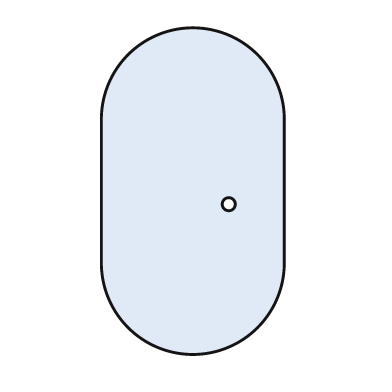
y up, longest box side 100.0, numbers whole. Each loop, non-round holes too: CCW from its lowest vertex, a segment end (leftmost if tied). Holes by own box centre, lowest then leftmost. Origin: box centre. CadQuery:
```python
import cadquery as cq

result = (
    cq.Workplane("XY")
    .moveTo(-28.0, -22.0)
    .threePointArc((0.0, -50.0), (28.0, -22.0))
    .lineTo(28.0, 22.0)
    .threePointArc((0.0, 50.0), (-28.0, 22.0))
    .close()
    .moveTo(11.0, -4.0)
    .circle(2.0)
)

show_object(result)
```